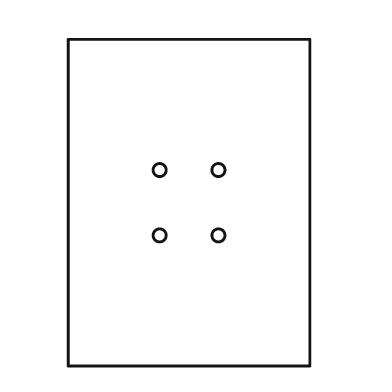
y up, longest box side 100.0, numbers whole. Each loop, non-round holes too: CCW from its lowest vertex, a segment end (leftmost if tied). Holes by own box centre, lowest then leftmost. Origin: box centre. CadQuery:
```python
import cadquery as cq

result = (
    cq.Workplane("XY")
    .moveTo(-37.0, -50.0)
    .lineTo(37.0, -50.0)
    .lineTo(37.0, 50.0)
    .lineTo(-37.0, 50.0)
    .close()
    .moveTo(-9.0, -10.0)
    .circle(2.0)
    .moveTo(9.0, -10.0)
    .circle(2.0)
    .moveTo(-9.0, 10.0)
    .circle(2.0)
    .moveTo(9.0, 10.0)
    .circle(2.0)
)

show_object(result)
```